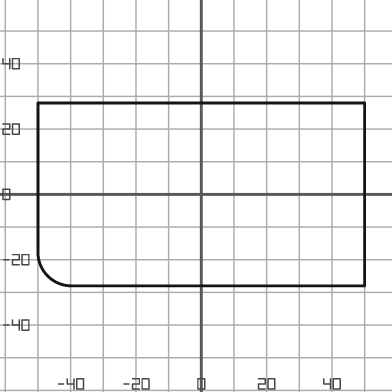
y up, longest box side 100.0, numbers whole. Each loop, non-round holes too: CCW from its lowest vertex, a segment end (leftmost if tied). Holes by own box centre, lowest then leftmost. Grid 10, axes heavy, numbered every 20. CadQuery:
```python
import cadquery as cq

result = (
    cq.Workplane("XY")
    .moveTo(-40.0, -28.0)
    .lineTo(50.0, -28.0)
    .lineTo(50.0, 28.0)
    .lineTo(-50.0, 28.0)
    .lineTo(-50.0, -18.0)
    .threePointArc((-47.0, -25.0), (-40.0, -28.0))
    .close()
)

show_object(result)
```